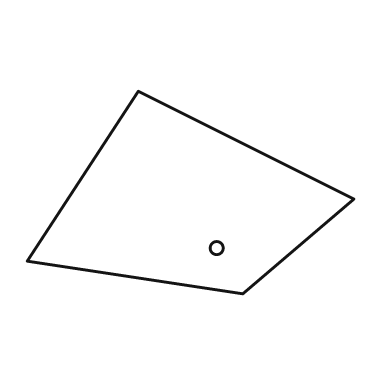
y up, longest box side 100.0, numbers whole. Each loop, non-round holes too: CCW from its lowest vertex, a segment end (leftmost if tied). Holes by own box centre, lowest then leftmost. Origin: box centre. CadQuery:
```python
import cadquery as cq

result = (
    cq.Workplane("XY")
    .moveTo(16.0, -31.0)
    .lineTo(50.0, -2.0)
    .lineTo(-16.0, 31.0)
    .lineTo(-50.0, -21.0)
    .close()
    .moveTo(8.0, -17.0)
    .circle(2.0)
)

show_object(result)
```